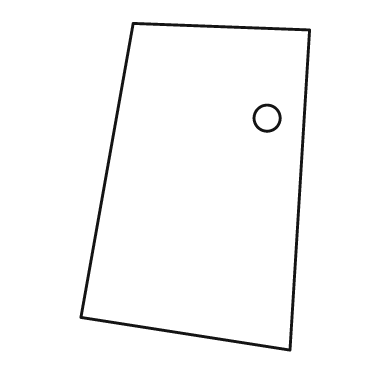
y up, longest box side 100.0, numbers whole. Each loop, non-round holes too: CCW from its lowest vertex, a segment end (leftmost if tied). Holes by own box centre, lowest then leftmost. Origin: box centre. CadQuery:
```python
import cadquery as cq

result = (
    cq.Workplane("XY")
    .moveTo(29.0, -50.0)
    .lineTo(35.0, 48.0)
    .lineTo(-19.0, 50.0)
    .lineTo(-35.0, -40.0)
    .close()
    .moveTo(22.0, 21.0)
    .circle(4.0)
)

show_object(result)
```